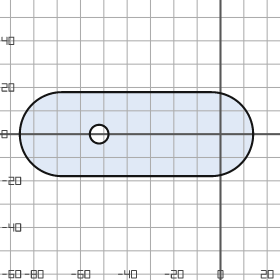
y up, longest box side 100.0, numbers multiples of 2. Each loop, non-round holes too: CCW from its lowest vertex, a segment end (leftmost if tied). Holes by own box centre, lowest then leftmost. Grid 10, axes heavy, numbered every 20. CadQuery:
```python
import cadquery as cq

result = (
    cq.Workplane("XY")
    .moveTo(-68.0, -18.0)
    .lineTo(-4.0, -18.0)
    .threePointArc((14.0, 0.0), (-4.0, 18.0))
    .lineTo(-68.0, 18.0)
    .threePointArc((-86.0, 0.0), (-68.0, -18.0))
    .close()
    .moveTo(-52.0, 0.0)
    .circle(4.0)
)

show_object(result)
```